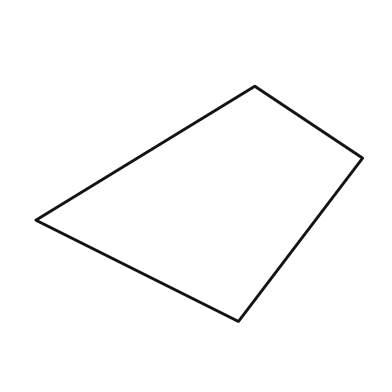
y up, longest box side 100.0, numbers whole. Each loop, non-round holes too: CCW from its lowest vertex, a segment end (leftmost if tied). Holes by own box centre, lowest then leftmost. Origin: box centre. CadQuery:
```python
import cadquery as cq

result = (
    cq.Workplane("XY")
    .moveTo(12.0, -36.0)
    .lineTo(50.0, 14.0)
    .lineTo(17.0, 36.0)
    .lineTo(-50.0, -5.0)
    .close()
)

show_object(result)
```